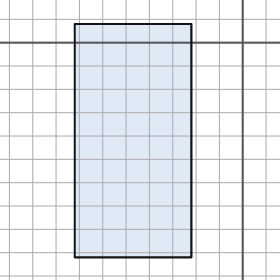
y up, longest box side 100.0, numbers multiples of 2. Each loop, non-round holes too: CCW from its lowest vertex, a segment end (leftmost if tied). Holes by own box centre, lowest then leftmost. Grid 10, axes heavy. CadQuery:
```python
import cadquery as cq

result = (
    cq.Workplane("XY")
    .moveTo(-72.0, -92.0)
    .lineTo(-22.0, -92.0)
    .lineTo(-22.0, 8.0)
    .lineTo(-72.0, 8.0)
    .close()
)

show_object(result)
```